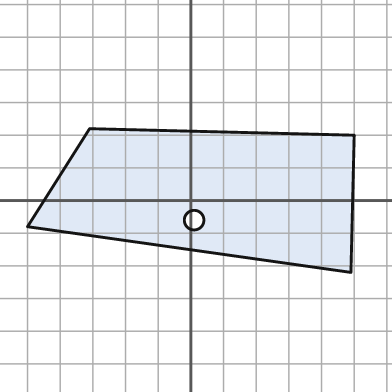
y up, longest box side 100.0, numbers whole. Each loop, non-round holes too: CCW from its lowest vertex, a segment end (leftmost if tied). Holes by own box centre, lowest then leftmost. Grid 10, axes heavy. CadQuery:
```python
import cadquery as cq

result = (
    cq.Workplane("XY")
    .moveTo(49.0, -22.0)
    .lineTo(50.0, 20.0)
    .lineTo(-31.0, 22.0)
    .lineTo(-50.0, -8.0)
    .close()
    .moveTo(1.0, -6.0)
    .circle(3.0)
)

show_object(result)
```